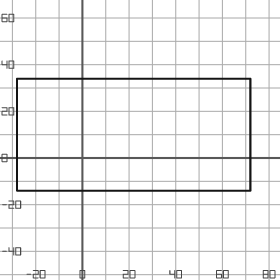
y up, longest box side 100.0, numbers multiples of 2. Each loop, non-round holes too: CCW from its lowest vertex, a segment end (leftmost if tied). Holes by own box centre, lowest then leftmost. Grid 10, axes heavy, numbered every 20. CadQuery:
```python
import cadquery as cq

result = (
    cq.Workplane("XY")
    .moveTo(-28.0, -14.0)
    .lineTo(72.0, -14.0)
    .lineTo(72.0, 34.0)
    .lineTo(-28.0, 34.0)
    .close()
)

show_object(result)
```